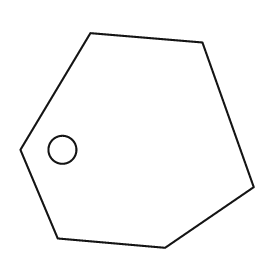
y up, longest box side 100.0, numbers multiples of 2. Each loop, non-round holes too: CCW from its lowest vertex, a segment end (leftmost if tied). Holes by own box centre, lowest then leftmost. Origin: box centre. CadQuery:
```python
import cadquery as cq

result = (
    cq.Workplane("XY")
    .moveTo(12.0, -46.0)
    .lineTo(50.0, -20.0)
    .lineTo(28.0, 42.0)
    .lineTo(-20.0, 46.0)
    .lineTo(-50.0, -4.0)
    .lineTo(-34.0, -42.0)
    .close()
    .moveTo(-32.0, -4.0)
    .circle(6.0)
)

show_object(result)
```